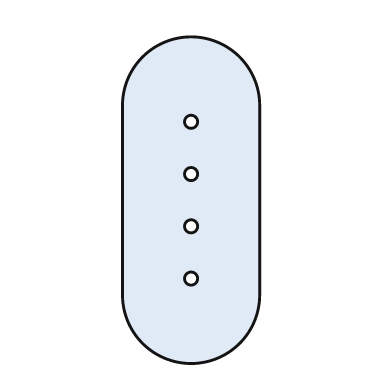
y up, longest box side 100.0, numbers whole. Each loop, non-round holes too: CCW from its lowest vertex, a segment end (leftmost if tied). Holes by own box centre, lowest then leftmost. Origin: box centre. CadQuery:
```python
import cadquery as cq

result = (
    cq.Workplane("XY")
    .moveTo(-21.0, -29.0)
    .threePointArc((0.0, -50.0), (21.0, -29.0))
    .lineTo(21.0, 29.0)
    .threePointArc((0.0, 50.0), (-21.0, 29.0))
    .close()
    .moveTo(0.0, -24.0)
    .circle(2.0)
    .moveTo(0.0, -8.0)
    .circle(2.0)
    .moveTo(0.0, 8.0)
    .circle(2.0)
    .moveTo(0.0, 24.0)
    .circle(2.0)
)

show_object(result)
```